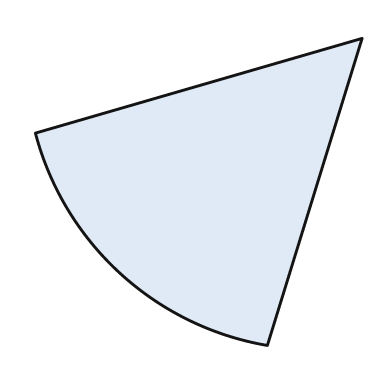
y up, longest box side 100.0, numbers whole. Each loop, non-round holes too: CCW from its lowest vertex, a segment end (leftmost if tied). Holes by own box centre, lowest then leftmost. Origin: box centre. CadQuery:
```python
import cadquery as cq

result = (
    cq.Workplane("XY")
    .moveTo(21.0, -47.0)
    .lineTo(50.0, 47.0)
    .lineTo(-50.0, 18.0)
    .threePointArc((-24.0, -25.0), (21.0, -47.0))
    .close()
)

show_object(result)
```